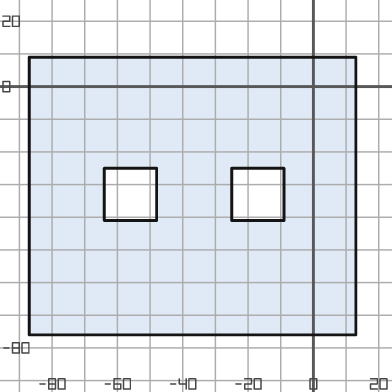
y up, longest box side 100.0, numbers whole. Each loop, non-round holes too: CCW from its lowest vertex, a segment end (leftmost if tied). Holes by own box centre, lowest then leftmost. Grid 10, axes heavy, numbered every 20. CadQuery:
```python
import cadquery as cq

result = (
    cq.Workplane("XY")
    .moveTo(-87.0, -76.0)
    .lineTo(13.0, -76.0)
    .lineTo(13.0, 9.0)
    .lineTo(-87.0, 9.0)
    .close()
    .moveTo(-64.0, -41.0)
    .lineTo(-48.0, -41.0)
    .lineTo(-48.0, -25.0)
    .lineTo(-64.0, -25.0)
    .close()
    .moveTo(-25.0, -41.0)
    .lineTo(-9.0, -41.0)
    .lineTo(-9.0, -25.0)
    .lineTo(-25.0, -25.0)
    .close()
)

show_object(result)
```